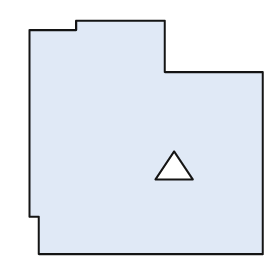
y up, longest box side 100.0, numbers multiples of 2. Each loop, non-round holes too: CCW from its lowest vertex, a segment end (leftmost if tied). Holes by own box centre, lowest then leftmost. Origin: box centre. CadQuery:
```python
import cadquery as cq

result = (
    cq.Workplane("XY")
    .moveTo(-46.0, -50.0)
    .lineTo(50.0, -50.0)
    .lineTo(50.0, 28.0)
    .lineTo(8.0, 28.0)
    .lineTo(8.0, 50.0)
    .lineTo(-30.0, 50.0)
    .lineTo(-30.0, 46.0)
    .lineTo(-50.0, 46.0)
    .lineTo(-50.0, -34.0)
    .lineTo(-46.0, -34.0)
    .close()
    .moveTo(4.0, -18.0)
    .lineTo(20.0, -18.0)
    .lineTo(12.0, -6.0)
    .close()
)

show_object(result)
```